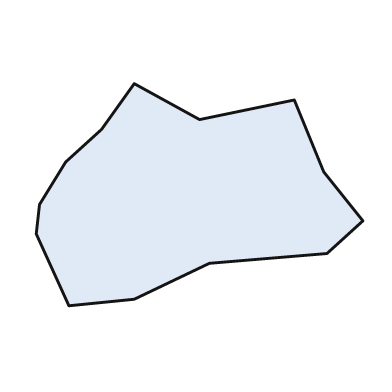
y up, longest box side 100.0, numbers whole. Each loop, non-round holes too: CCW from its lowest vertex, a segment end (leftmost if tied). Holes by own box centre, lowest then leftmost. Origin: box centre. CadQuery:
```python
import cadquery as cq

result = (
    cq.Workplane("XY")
    .moveTo(-40.0, -34.0)
    .lineTo(-20.0, -32.0)
    .lineTo(3.0, -21.0)
    .lineTo(39.0, -18.0)
    .lineTo(50.0, -8.0)
    .lineTo(38.0, 7.0)
    .lineTo(29.0, 29.0)
    .lineTo(0.0, 23.0)
    .lineTo(-20.0, 34.0)
    .lineTo(-30.0, 20.0)
    .lineTo(-41.0, 10.0)
    .lineTo(-49.0, -3.0)
    .lineTo(-50.0, -12.0)
    .close()
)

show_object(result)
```